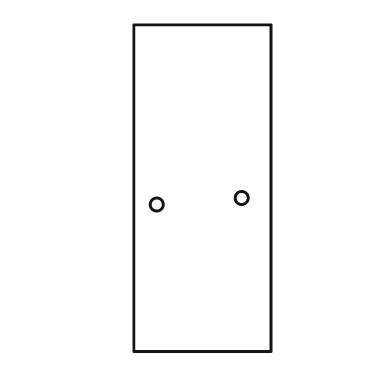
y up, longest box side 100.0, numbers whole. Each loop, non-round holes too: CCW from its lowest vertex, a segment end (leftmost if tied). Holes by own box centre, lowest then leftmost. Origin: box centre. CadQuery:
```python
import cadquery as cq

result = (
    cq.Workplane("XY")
    .moveTo(-21.0, -50.0)
    .lineTo(21.0, -50.0)
    .lineTo(21.0, 50.0)
    .lineTo(-21.0, 50.0)
    .close()
    .moveTo(-14.0, -5.0)
    .circle(2.0)
    .moveTo(12.0, -3.0)
    .circle(2.0)
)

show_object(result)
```